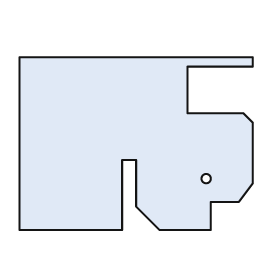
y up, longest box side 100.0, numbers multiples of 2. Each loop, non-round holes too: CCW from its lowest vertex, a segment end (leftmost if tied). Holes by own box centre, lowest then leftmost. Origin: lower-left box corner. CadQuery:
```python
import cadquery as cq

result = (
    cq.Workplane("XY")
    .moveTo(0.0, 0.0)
    .lineTo(44.0, 0.0)
    .lineTo(44.0, 30.0)
    .lineTo(50.0, 30.0)
    .lineTo(50.0, 10.0)
    .lineTo(60.0, 0.0)
    .lineTo(82.0, 0.0)
    .lineTo(82.0, 12.0)
    .lineTo(94.0, 12.0)
    .lineTo(100.0, 20.0)
    .lineTo(100.0, 46.0)
    .lineTo(96.0, 50.0)
    .lineTo(72.0, 50.0)
    .lineTo(72.0, 70.0)
    .lineTo(100.0, 70.0)
    .lineTo(100.0, 74.0)
    .lineTo(0.0, 74.0)
    .close()
    .moveTo(80.0, 22.0)
    .circle(2.0)
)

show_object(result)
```